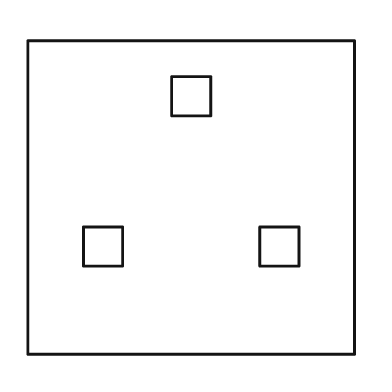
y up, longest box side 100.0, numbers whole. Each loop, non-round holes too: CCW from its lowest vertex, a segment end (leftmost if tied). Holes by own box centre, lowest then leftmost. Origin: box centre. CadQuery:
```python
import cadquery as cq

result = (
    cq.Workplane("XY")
    .moveTo(-50.0, -48.0)
    .lineTo(50.0, -48.0)
    .lineTo(50.0, 48.0)
    .lineTo(-50.0, 48.0)
    .close()
    .moveTo(-33.0, -21.0)
    .lineTo(-21.0, -21.0)
    .lineTo(-21.0, -9.0)
    .lineTo(-33.0, -9.0)
    .close()
    .moveTo(21.0, -21.0)
    .lineTo(33.0, -21.0)
    .lineTo(33.0, -9.0)
    .lineTo(21.0, -9.0)
    .close()
    .moveTo(-6.0, 25.0)
    .lineTo(6.0, 25.0)
    .lineTo(6.0, 37.0)
    .lineTo(-6.0, 37.0)
    .close()
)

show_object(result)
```